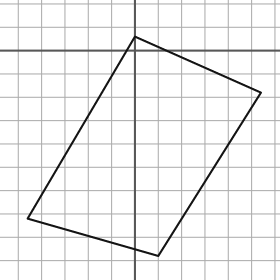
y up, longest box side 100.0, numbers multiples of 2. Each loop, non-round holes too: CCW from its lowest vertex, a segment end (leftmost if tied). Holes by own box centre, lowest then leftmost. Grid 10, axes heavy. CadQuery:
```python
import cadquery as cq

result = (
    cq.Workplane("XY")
    .moveTo(10.0, -88.0)
    .lineTo(54.0, -18.0)
    .lineTo(0.0, 6.0)
    .lineTo(-46.0, -72.0)
    .close()
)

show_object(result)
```